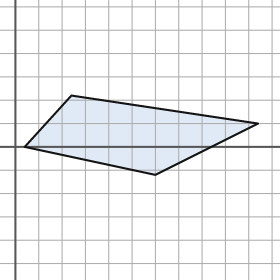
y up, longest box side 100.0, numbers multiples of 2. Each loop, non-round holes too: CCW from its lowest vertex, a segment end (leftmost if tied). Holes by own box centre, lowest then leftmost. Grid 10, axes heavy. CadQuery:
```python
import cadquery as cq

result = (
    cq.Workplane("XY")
    .moveTo(60.0, -12.0)
    .lineTo(104.0, 10.0)
    .lineTo(24.0, 22.0)
    .lineTo(4.0, 0.0)
    .close()
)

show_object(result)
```